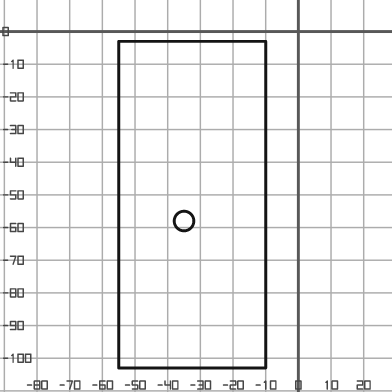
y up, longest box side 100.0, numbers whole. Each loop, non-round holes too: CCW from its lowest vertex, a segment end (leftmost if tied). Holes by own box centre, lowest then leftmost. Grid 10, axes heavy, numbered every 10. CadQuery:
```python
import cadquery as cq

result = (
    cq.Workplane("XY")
    .moveTo(-55.0, -103.0)
    .lineTo(-10.0, -103.0)
    .lineTo(-10.0, -3.0)
    .lineTo(-55.0, -3.0)
    .close()
    .moveTo(-35.0, -58.0)
    .circle(3.0)
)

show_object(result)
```